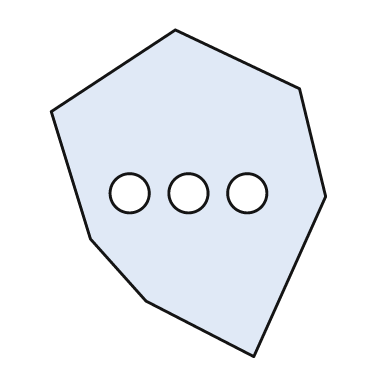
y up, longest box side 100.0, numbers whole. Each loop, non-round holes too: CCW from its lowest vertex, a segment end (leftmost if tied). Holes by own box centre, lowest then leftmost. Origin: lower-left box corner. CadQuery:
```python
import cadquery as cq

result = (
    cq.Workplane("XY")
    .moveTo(62.0, 0.0)
    .lineTo(84.0, 49.0)
    .lineTo(76.0, 82.0)
    .lineTo(38.0, 100.0)
    .lineTo(0.0, 75.0)
    .lineTo(12.0, 36.0)
    .lineTo(29.0, 17.0)
    .close()
    .moveTo(24.0, 50.0)
    .circle(6.0)
    .moveTo(42.0, 50.0)
    .circle(6.0)
    .moveTo(60.0, 50.0)
    .circle(6.0)
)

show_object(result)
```